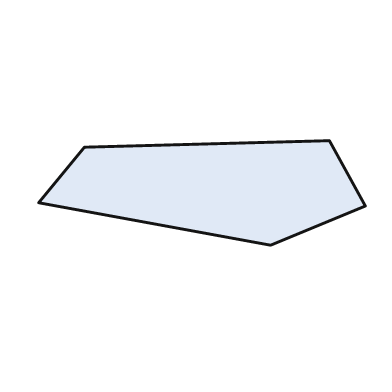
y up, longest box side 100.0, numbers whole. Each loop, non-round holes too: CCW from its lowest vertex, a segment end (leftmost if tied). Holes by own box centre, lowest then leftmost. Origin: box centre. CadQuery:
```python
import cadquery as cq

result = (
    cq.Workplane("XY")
    .moveTo(21.0, -16.0)
    .lineTo(50.0, -4.0)
    .lineTo(39.0, 16.0)
    .lineTo(-36.0, 14.0)
    .lineTo(-50.0, -3.0)
    .close()
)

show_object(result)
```